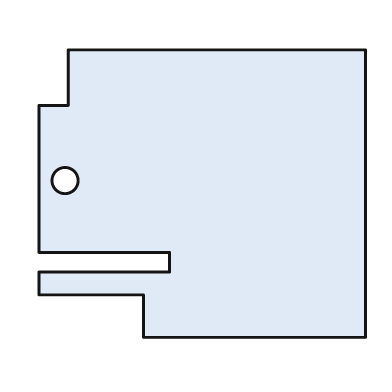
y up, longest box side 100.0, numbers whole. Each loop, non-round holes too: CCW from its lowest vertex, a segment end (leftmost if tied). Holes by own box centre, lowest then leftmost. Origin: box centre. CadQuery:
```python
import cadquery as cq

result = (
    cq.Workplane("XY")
    .moveTo(-18.0, -44.0)
    .lineTo(50.0, -44.0)
    .lineTo(50.0, 44.0)
    .lineTo(-41.0, 44.0)
    .lineTo(-41.0, 27.0)
    .lineTo(-50.0, 27.0)
    .lineTo(-50.0, -18.0)
    .lineTo(-10.0, -18.0)
    .lineTo(-10.0, -24.0)
    .lineTo(-50.0, -24.0)
    .lineTo(-50.0, -31.0)
    .lineTo(-18.0, -31.0)
    .close()
    .moveTo(-42.0, 4.0)
    .circle(4.0)
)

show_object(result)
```